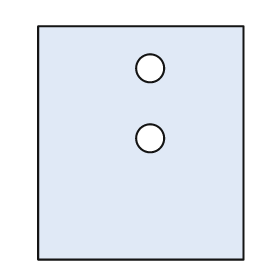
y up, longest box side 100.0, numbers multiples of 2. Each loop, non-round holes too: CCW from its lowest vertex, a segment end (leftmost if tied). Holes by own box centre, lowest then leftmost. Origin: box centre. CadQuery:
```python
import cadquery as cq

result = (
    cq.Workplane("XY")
    .moveTo(-44.0, -50.0)
    .lineTo(44.0, -50.0)
    .lineTo(44.0, 50.0)
    .lineTo(-44.0, 50.0)
    .close()
    .moveTo(4.0, 2.0)
    .circle(6.0)
    .moveTo(4.0, 32.0)
    .circle(6.0)
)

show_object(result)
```